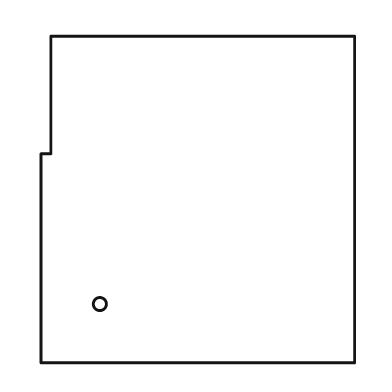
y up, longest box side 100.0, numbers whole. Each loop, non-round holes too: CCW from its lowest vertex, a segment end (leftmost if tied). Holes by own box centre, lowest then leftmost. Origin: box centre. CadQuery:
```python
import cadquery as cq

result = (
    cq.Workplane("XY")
    .moveTo(-48.0, -50.0)
    .lineTo(48.0, -50.0)
    .lineTo(48.0, 50.0)
    .lineTo(-45.0, 50.0)
    .lineTo(-45.0, 14.0)
    .lineTo(-48.0, 14.0)
    .close()
    .moveTo(-30.0, -32.0)
    .circle(2.0)
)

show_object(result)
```